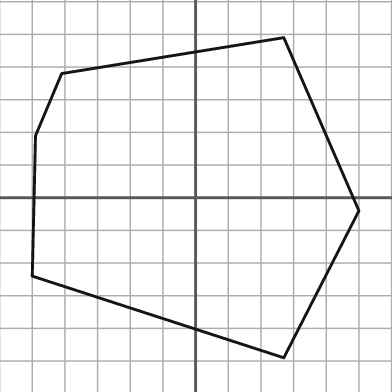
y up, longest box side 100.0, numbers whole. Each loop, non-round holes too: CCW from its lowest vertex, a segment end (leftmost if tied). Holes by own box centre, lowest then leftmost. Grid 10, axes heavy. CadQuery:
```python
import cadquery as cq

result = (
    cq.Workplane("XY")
    .moveTo(27.0, -49.0)
    .lineTo(50.0, -4.0)
    .lineTo(27.0, 49.0)
    .lineTo(-41.0, 38.0)
    .lineTo(-49.0, 19.0)
    .lineTo(-50.0, -24.0)
    .close()
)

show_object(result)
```